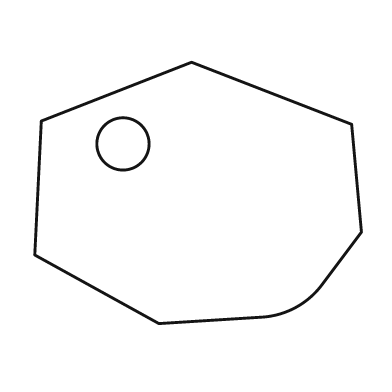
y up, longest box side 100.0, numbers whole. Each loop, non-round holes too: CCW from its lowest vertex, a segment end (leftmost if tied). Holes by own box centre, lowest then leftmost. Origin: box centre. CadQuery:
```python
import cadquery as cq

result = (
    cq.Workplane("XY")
    .moveTo(-12.0, -40.0)
    .lineTo(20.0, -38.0)
    .threePointArc((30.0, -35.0), (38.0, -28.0))
    .lineTo(50.0, -12.0)
    .lineTo(47.0, 21.0)
    .lineTo(-2.0, 40.0)
    .lineTo(-48.0, 22.0)
    .lineTo(-50.0, -19.0)
    .close()
    .moveTo(-23.0, 15.0)
    .circle(8.0)
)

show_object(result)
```